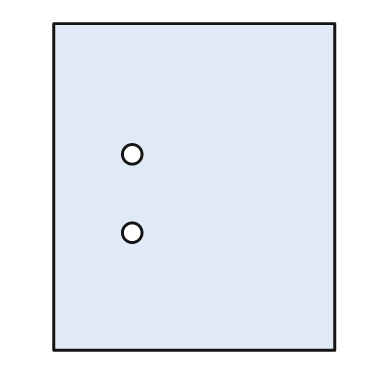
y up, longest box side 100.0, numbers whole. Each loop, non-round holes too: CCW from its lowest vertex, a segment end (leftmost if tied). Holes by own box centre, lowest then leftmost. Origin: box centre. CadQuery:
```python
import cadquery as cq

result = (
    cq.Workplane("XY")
    .moveTo(-43.0, -50.0)
    .lineTo(43.0, -50.0)
    .lineTo(43.0, 50.0)
    .lineTo(-43.0, 50.0)
    .close()
    .moveTo(-19.0, -14.0)
    .circle(3.0)
    .moveTo(-19.0, 10.0)
    .circle(3.0)
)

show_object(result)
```